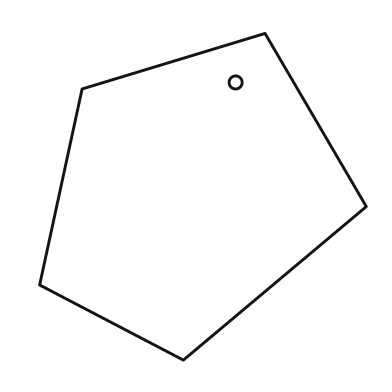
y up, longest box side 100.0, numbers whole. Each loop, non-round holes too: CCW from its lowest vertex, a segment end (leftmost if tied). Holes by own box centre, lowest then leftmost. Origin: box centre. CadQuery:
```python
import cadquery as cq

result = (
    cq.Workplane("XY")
    .moveTo(-6.0, -50.0)
    .lineTo(50.0, -3.0)
    .lineTo(19.0, 50.0)
    .lineTo(-37.0, 33.0)
    .lineTo(-50.0, -27.0)
    .close()
    .moveTo(10.0, 35.0)
    .circle(2.0)
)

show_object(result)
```